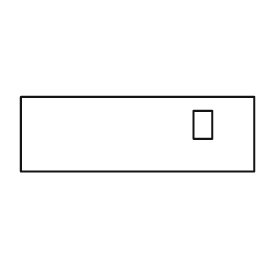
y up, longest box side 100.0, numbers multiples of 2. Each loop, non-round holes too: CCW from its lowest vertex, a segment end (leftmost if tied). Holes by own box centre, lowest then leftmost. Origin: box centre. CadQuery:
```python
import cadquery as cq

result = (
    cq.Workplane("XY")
    .moveTo(-50.0, -16.0)
    .lineTo(50.0, -16.0)
    .lineTo(50.0, 16.0)
    .lineTo(-50.0, 16.0)
    .close()
    .moveTo(24.0, -2.0)
    .lineTo(32.0, -2.0)
    .lineTo(32.0, 10.0)
    .lineTo(24.0, 10.0)
    .close()
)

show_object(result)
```